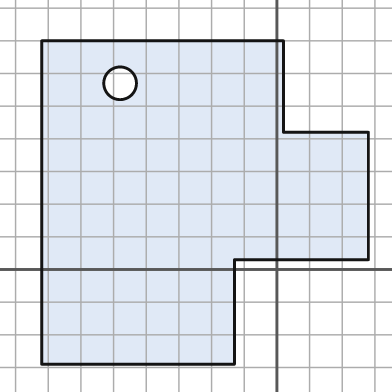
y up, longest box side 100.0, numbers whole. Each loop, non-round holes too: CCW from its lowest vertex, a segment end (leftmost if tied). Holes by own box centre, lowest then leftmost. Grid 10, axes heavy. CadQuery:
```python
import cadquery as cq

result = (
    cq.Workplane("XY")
    .moveTo(-72.0, -29.0)
    .lineTo(-13.0, -29.0)
    .lineTo(-13.0, 3.0)
    .lineTo(28.0, 3.0)
    .lineTo(28.0, 42.0)
    .lineTo(2.0, 42.0)
    .lineTo(2.0, 70.0)
    .lineTo(-72.0, 70.0)
    .close()
    .moveTo(-48.0, 57.0)
    .circle(5.0)
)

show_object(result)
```